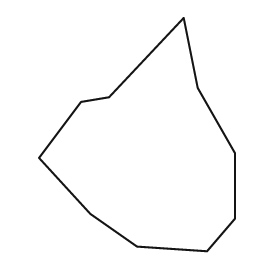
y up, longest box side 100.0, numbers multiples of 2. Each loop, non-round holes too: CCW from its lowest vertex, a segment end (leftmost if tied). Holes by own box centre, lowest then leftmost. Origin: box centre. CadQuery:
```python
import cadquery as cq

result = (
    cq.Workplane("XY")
    .moveTo(30.0, -50.0)
    .lineTo(42.0, -36.0)
    .lineTo(42.0, -8.0)
    .lineTo(26.0, 20.0)
    .lineTo(20.0, 50.0)
    .lineTo(-12.0, 16.0)
    .lineTo(-24.0, 14.0)
    .lineTo(-42.0, -10.0)
    .lineTo(-20.0, -34.0)
    .lineTo(0.0, -48.0)
    .close()
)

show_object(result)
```